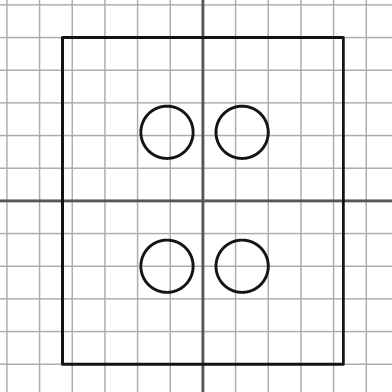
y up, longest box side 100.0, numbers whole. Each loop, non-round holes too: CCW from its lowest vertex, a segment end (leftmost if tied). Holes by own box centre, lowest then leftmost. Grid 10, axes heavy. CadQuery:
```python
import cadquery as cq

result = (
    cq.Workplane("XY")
    .moveTo(-43.0, -50.0)
    .lineTo(43.0, -50.0)
    .lineTo(43.0, 50.0)
    .lineTo(-43.0, 50.0)
    .close()
    .moveTo(-11.0, -20.0)
    .circle(8.0)
    .moveTo(12.0, -20.0)
    .circle(8.0)
    .moveTo(-11.0, 21.0)
    .circle(8.0)
    .moveTo(12.0, 21.0)
    .circle(8.0)
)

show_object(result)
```